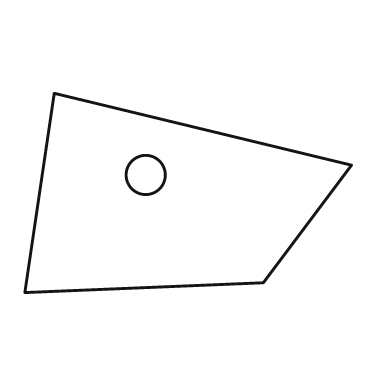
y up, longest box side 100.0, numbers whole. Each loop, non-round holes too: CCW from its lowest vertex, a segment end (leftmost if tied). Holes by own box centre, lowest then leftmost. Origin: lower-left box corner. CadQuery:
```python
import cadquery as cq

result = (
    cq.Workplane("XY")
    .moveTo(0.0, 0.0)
    .lineTo(73.0, 3.0)
    .lineTo(100.0, 39.0)
    .lineTo(9.0, 61.0)
    .close()
    .moveTo(37.0, 36.0)
    .circle(6.0)
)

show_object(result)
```